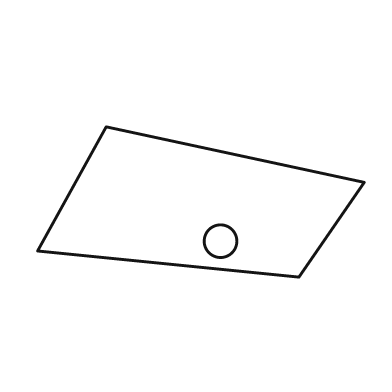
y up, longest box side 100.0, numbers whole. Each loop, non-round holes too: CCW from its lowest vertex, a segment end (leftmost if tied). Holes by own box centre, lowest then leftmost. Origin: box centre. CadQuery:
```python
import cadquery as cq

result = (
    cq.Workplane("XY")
    .moveTo(30.0, -23.0)
    .lineTo(50.0, 6.0)
    .lineTo(-29.0, 23.0)
    .lineTo(-50.0, -15.0)
    .close()
    .moveTo(6.0, -12.0)
    .circle(5.0)
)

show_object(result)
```